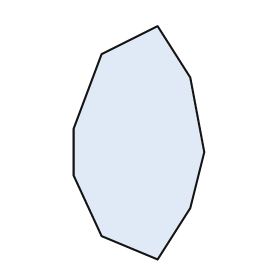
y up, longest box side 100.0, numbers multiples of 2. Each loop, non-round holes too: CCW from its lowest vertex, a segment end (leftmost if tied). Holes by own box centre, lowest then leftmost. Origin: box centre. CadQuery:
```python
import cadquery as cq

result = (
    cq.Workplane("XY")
    .moveTo(8.0, -50.0)
    .lineTo(22.0, -28.0)
    .lineTo(28.0, -4.0)
    .lineTo(22.0, 28.0)
    .lineTo(8.0, 50.0)
    .lineTo(-16.0, 38.0)
    .lineTo(-28.0, 6.0)
    .lineTo(-28.0, -14.0)
    .lineTo(-16.0, -40.0)
    .close()
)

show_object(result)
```